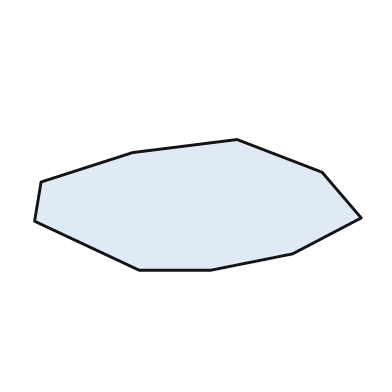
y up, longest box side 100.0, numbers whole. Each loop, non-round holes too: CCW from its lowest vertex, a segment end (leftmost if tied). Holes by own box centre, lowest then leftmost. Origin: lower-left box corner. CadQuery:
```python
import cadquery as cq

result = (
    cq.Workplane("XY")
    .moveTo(32.0, 0.0)
    .lineTo(54.0, 0.0)
    .lineTo(79.0, 5.0)
    .lineTo(100.0, 16.0)
    .lineTo(88.0, 30.0)
    .lineTo(62.0, 40.0)
    .lineTo(30.0, 36.0)
    .lineTo(2.0, 27.0)
    .lineTo(0.0, 15.0)
    .close()
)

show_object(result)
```